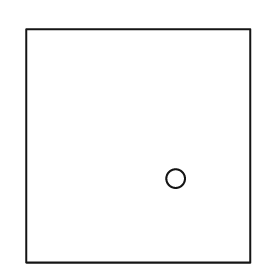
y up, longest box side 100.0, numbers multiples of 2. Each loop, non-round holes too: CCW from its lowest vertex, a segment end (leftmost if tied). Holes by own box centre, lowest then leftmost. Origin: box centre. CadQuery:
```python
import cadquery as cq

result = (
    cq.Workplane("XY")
    .moveTo(-48.0, -50.0)
    .lineTo(48.0, -50.0)
    .lineTo(48.0, 50.0)
    .lineTo(-48.0, 50.0)
    .close()
    .moveTo(16.0, -14.0)
    .circle(4.0)
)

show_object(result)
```